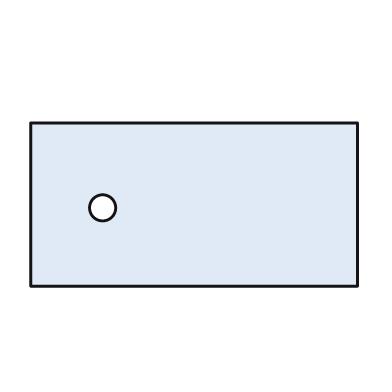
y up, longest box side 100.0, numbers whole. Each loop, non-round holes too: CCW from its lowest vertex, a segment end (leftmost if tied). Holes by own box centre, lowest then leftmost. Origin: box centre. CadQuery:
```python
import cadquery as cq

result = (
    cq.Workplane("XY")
    .moveTo(-50.0, -25.0)
    .lineTo(50.0, -25.0)
    .lineTo(50.0, 25.0)
    .lineTo(-50.0, 25.0)
    .close()
    .moveTo(-28.0, -1.0)
    .circle(4.0)
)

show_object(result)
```